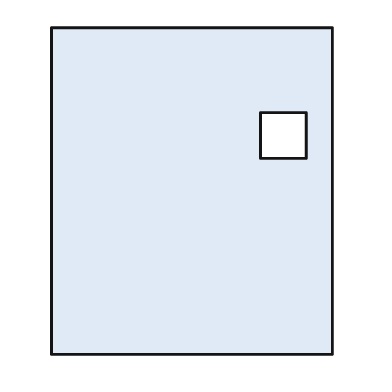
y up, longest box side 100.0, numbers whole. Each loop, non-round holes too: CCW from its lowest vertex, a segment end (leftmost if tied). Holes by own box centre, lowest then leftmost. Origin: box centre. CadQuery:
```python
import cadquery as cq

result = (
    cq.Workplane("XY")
    .moveTo(-43.0, -50.0)
    .lineTo(43.0, -50.0)
    .lineTo(43.0, 50.0)
    .lineTo(-43.0, 50.0)
    .close()
    .moveTo(21.0, 10.0)
    .lineTo(35.0, 10.0)
    .lineTo(35.0, 24.0)
    .lineTo(21.0, 24.0)
    .close()
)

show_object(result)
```